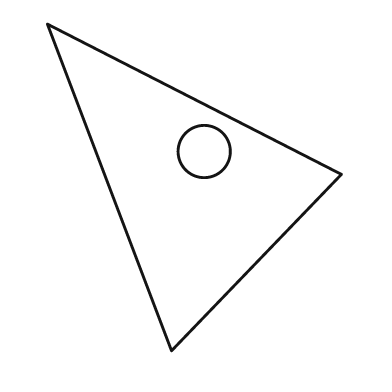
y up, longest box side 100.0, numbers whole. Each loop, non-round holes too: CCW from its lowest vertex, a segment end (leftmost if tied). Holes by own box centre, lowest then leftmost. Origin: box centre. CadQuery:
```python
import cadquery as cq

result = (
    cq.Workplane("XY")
    .moveTo(-7.0, -50.0)
    .lineTo(45.0, 4.0)
    .lineTo(-45.0, 50.0)
    .close()
    .moveTo(3.0, 11.0)
    .circle(8.0)
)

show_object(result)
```